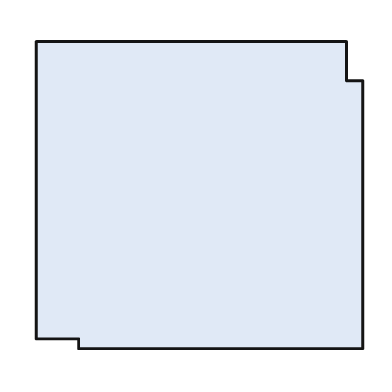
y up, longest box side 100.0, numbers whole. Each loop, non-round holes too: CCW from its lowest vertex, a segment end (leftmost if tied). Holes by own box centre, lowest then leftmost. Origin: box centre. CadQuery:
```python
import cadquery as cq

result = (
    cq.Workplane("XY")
    .moveTo(-37.0, -47.0)
    .lineTo(50.0, -47.0)
    .lineTo(50.0, 35.0)
    .lineTo(45.0, 35.0)
    .lineTo(45.0, 47.0)
    .lineTo(-50.0, 47.0)
    .lineTo(-50.0, -44.0)
    .lineTo(-37.0, -44.0)
    .close()
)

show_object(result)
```